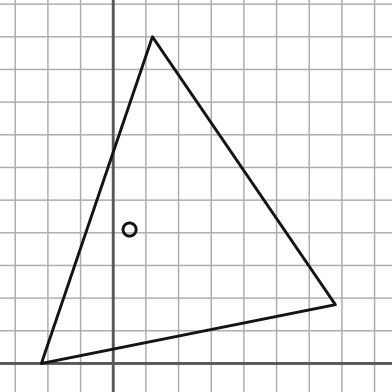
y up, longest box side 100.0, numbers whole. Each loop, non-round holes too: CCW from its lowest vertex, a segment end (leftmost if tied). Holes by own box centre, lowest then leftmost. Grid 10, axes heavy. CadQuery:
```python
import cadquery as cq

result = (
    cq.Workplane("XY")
    .moveTo(-22.0, 0.0)
    .lineTo(68.0, 18.0)
    .lineTo(12.0, 100.0)
    .close()
    .moveTo(5.0, 41.0)
    .circle(2.0)
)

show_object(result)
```